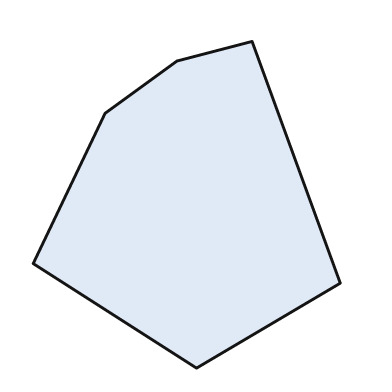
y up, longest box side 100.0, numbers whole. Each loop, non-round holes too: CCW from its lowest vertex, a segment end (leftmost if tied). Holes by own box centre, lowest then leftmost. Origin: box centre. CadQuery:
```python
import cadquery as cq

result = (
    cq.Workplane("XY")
    .moveTo(3.0, -50.0)
    .lineTo(47.0, -24.0)
    .lineTo(20.0, 50.0)
    .lineTo(-3.0, 44.0)
    .lineTo(-25.0, 28.0)
    .lineTo(-47.0, -18.0)
    .close()
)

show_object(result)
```